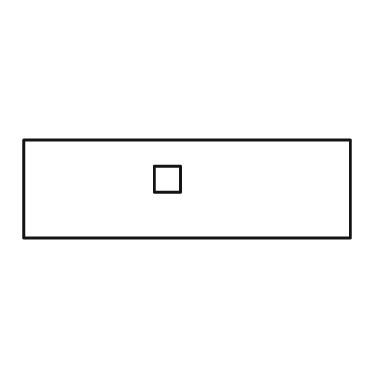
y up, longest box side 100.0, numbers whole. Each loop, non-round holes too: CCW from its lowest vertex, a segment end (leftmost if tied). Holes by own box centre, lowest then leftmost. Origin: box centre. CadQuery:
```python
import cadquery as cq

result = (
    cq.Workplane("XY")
    .moveTo(-50.0, -15.0)
    .lineTo(50.0, -15.0)
    .lineTo(50.0, 15.0)
    .lineTo(-50.0, 15.0)
    .close()
    .moveTo(-10.0, -1.0)
    .lineTo(-2.0, -1.0)
    .lineTo(-2.0, 7.0)
    .lineTo(-10.0, 7.0)
    .close()
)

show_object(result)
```